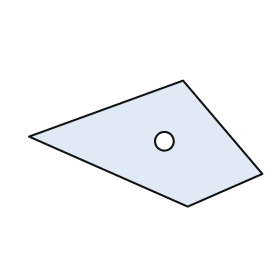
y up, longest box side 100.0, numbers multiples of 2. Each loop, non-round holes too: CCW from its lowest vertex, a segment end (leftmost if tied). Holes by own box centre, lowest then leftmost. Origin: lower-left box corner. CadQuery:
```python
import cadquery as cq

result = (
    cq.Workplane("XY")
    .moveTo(68.0, 0.0)
    .lineTo(100.0, 14.0)
    .lineTo(66.0, 54.0)
    .lineTo(0.0, 30.0)
    .close()
    .moveTo(58.0, 28.0)
    .circle(4.0)
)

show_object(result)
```